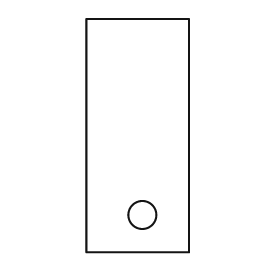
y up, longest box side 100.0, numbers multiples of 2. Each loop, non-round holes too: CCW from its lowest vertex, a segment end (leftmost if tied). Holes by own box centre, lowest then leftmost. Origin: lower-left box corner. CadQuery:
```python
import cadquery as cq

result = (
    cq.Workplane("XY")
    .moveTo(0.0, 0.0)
    .lineTo(44.0, 0.0)
    .lineTo(44.0, 100.0)
    .lineTo(0.0, 100.0)
    .close()
    .moveTo(24.0, 16.0)
    .circle(6.0)
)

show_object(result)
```